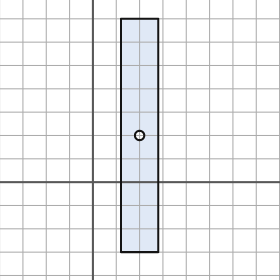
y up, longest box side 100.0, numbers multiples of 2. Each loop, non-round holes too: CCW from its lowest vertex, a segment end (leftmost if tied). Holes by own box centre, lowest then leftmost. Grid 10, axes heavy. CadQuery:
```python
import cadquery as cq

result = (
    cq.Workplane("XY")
    .moveTo(12.0, -30.0)
    .lineTo(28.0, -30.0)
    .lineTo(28.0, 70.0)
    .lineTo(12.0, 70.0)
    .close()
    .moveTo(20.0, 20.0)
    .circle(2.0)
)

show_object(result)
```